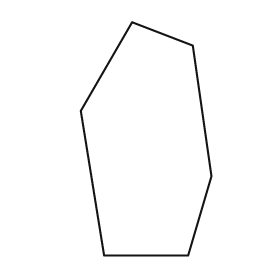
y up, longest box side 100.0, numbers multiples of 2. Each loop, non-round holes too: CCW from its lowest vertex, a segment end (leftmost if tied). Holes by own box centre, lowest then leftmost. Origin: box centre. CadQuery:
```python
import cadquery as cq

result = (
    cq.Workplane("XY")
    .moveTo(-18.0, -50.0)
    .lineTo(18.0, -50.0)
    .lineTo(28.0, -16.0)
    .lineTo(20.0, 40.0)
    .lineTo(-6.0, 50.0)
    .lineTo(-28.0, 12.0)
    .close()
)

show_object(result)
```